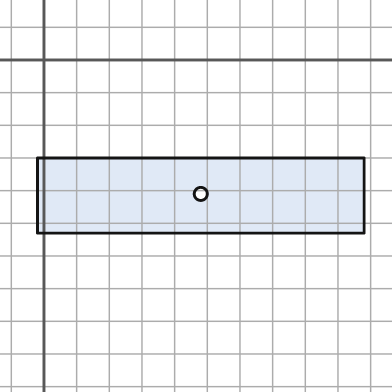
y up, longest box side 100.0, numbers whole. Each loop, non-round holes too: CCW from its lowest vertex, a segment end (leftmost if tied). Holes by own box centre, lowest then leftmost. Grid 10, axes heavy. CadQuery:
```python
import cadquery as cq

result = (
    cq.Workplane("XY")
    .moveTo(-2.0, -53.0)
    .lineTo(98.0, -53.0)
    .lineTo(98.0, -30.0)
    .lineTo(-2.0, -30.0)
    .close()
    .moveTo(48.0, -41.0)
    .circle(2.0)
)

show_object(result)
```